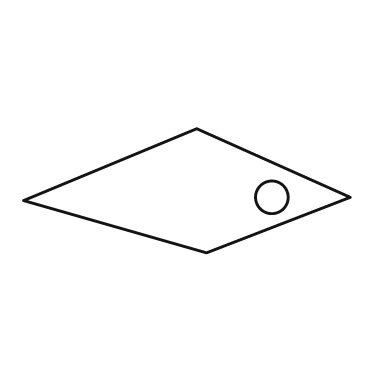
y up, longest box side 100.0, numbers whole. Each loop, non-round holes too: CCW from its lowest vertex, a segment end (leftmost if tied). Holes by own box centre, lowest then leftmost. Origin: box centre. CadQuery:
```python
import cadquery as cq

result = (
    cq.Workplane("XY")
    .moveTo(6.0, -19.0)
    .lineTo(50.0, -2.0)
    .lineTo(3.0, 19.0)
    .lineTo(-50.0, -3.0)
    .close()
    .moveTo(26.0, -2.0)
    .circle(5.0)
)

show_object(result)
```